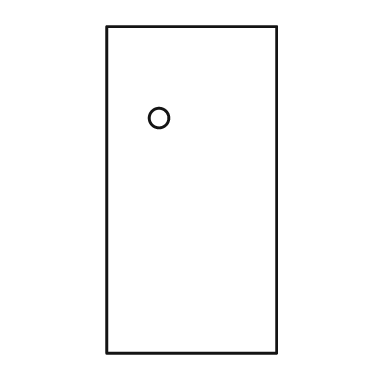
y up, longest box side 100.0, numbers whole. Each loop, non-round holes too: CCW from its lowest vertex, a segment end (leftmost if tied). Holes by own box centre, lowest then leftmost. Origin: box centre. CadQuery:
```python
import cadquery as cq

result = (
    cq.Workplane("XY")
    .moveTo(-26.0, -50.0)
    .lineTo(26.0, -50.0)
    .lineTo(26.0, 50.0)
    .lineTo(-26.0, 50.0)
    .close()
    .moveTo(-10.0, 22.0)
    .circle(3.0)
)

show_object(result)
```